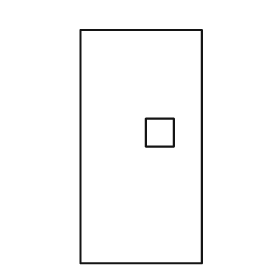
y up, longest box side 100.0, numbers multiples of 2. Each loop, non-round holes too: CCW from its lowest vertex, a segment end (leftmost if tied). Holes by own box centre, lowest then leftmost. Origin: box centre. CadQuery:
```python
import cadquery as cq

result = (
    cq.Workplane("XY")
    .moveTo(-26.0, -50.0)
    .lineTo(26.0, -50.0)
    .lineTo(26.0, 50.0)
    .lineTo(-26.0, 50.0)
    .close()
    .moveTo(2.0, 0.0)
    .lineTo(14.0, 0.0)
    .lineTo(14.0, 12.0)
    .lineTo(2.0, 12.0)
    .close()
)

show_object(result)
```